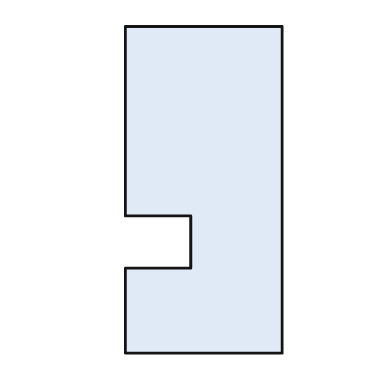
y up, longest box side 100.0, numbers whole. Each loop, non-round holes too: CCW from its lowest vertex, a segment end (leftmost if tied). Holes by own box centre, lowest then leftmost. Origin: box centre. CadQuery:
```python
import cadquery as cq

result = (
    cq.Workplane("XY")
    .moveTo(-24.0, -50.0)
    .lineTo(24.0, -50.0)
    .lineTo(24.0, 50.0)
    .lineTo(-24.0, 50.0)
    .lineTo(-24.0, -8.0)
    .lineTo(-4.0, -8.0)
    .lineTo(-4.0, -24.0)
    .lineTo(-24.0, -24.0)
    .close()
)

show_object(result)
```